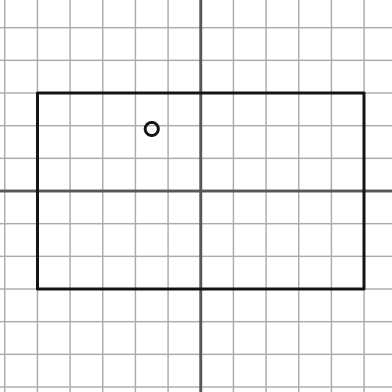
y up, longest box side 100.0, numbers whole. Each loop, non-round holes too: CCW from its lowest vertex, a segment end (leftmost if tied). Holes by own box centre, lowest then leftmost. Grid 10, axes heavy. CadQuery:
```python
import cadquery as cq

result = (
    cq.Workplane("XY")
    .moveTo(-50.0, -30.0)
    .lineTo(50.0, -30.0)
    .lineTo(50.0, 30.0)
    .lineTo(-50.0, 30.0)
    .close()
    .moveTo(-15.0, 19.0)
    .circle(2.0)
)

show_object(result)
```